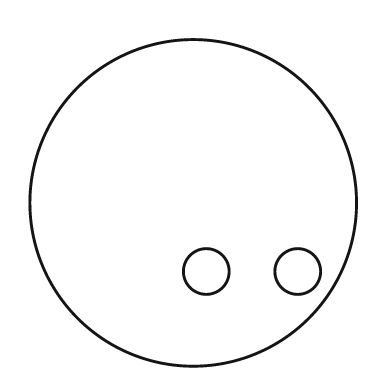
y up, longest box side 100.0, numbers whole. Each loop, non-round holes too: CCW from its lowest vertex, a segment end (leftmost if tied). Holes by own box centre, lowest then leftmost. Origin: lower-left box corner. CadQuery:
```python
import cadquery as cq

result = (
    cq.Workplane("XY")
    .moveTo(50.0, 50.0)
    .circle(50.0)
    .moveTo(54.0, 29.0)
    .circle(7.0)
    .moveTo(82.0, 29.0)
    .circle(7.0)
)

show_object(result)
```